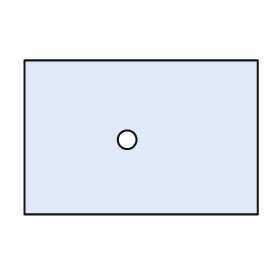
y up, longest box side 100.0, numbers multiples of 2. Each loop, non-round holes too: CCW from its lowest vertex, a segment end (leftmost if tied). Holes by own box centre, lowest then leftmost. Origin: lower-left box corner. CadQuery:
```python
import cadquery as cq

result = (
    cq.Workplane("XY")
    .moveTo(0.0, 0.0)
    .lineTo(100.0, 0.0)
    .lineTo(100.0, 66.0)
    .lineTo(0.0, 66.0)
    .close()
    .moveTo(44.0, 32.0)
    .circle(4.0)
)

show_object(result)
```